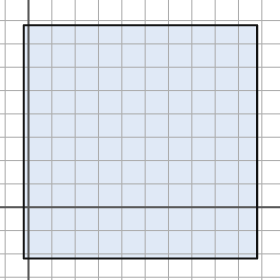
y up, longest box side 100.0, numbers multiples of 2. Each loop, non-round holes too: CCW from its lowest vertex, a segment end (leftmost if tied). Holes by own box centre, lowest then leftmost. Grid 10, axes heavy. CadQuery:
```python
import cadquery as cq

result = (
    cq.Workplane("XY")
    .moveTo(-2.0, -22.0)
    .lineTo(98.0, -22.0)
    .lineTo(98.0, 78.0)
    .lineTo(-2.0, 78.0)
    .close()
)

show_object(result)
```